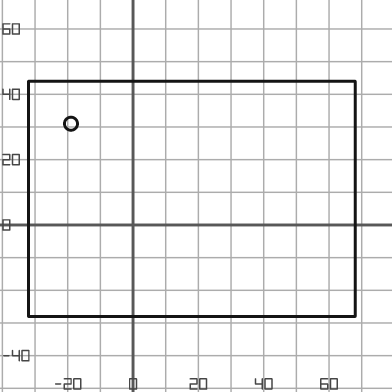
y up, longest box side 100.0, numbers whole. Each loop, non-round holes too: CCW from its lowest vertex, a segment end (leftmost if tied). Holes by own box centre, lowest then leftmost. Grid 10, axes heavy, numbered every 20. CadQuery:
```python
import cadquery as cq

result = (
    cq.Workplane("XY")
    .moveTo(-32.0, -28.0)
    .lineTo(68.0, -28.0)
    .lineTo(68.0, 44.0)
    .lineTo(-32.0, 44.0)
    .close()
    .moveTo(-19.0, 31.0)
    .circle(2.0)
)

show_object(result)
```